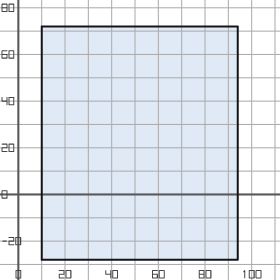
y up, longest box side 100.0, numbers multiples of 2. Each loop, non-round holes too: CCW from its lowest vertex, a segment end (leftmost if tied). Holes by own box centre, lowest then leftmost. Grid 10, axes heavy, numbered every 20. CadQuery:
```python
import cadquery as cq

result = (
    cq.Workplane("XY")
    .moveTo(10.0, -28.0)
    .lineTo(94.0, -28.0)
    .lineTo(94.0, 72.0)
    .lineTo(10.0, 72.0)
    .close()
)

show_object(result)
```